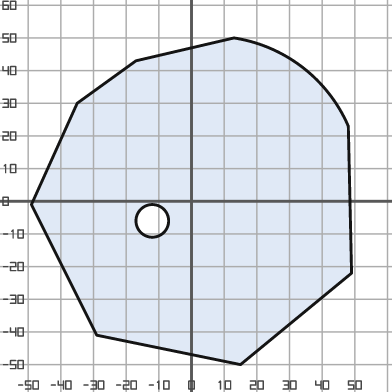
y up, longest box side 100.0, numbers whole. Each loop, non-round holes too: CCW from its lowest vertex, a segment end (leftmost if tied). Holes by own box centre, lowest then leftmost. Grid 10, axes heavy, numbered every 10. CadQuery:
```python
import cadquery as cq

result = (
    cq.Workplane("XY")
    .moveTo(15.0, -50.0)
    .lineTo(49.0, -22.0)
    .lineTo(48.0, 23.0)
    .threePointArc((34.0, 41.0), (13.0, 50.0))
    .lineTo(-17.0, 43.0)
    .lineTo(-35.0, 30.0)
    .lineTo(-49.0, -1.0)
    .lineTo(-29.0, -41.0)
    .close()
    .moveTo(-12.0, -6.0)
    .circle(5.0)
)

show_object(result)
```